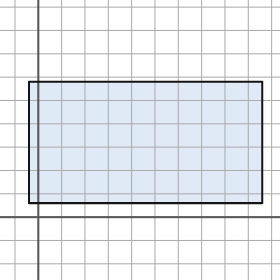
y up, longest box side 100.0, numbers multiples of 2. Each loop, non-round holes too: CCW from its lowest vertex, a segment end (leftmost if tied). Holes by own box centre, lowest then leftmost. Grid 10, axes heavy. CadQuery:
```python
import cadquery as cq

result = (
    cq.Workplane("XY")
    .moveTo(-4.0, 6.0)
    .lineTo(96.0, 6.0)
    .lineTo(96.0, 58.0)
    .lineTo(-4.0, 58.0)
    .close()
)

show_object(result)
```